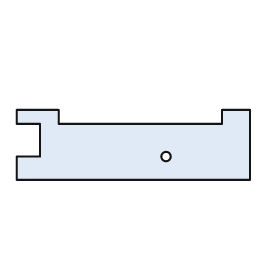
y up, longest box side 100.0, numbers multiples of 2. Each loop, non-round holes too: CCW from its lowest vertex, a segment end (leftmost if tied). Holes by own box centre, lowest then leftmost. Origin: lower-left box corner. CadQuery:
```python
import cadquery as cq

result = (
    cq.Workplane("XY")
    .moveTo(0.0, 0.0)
    .lineTo(100.0, 0.0)
    .lineTo(100.0, 30.0)
    .lineTo(88.0, 30.0)
    .lineTo(88.0, 24.0)
    .lineTo(18.0, 24.0)
    .lineTo(18.0, 30.0)
    .lineTo(0.0, 30.0)
    .lineTo(0.0, 24.0)
    .lineTo(10.0, 24.0)
    .lineTo(10.0, 10.0)
    .lineTo(0.0, 10.0)
    .close()
    .moveTo(64.0, 10.0)
    .circle(2.0)
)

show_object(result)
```